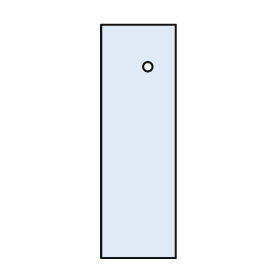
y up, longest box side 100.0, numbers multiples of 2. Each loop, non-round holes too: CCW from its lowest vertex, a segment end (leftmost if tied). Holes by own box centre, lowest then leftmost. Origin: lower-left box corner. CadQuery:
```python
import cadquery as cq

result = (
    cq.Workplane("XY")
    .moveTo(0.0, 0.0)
    .lineTo(32.0, 0.0)
    .lineTo(32.0, 100.0)
    .lineTo(0.0, 100.0)
    .close()
    .moveTo(20.0, 82.0)
    .circle(2.0)
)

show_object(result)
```